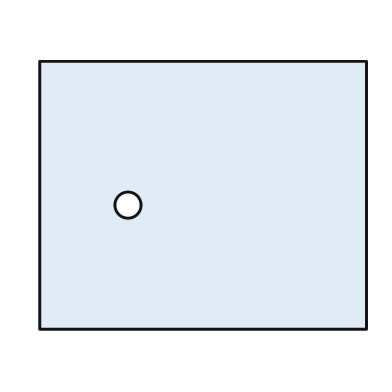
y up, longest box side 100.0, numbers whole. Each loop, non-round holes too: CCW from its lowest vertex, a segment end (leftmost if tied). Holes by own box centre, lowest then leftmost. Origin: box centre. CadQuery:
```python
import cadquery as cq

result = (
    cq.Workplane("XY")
    .moveTo(-50.0, -41.0)
    .lineTo(50.0, -41.0)
    .lineTo(50.0, 41.0)
    .lineTo(-50.0, 41.0)
    .close()
    .moveTo(-23.0, -3.0)
    .circle(4.0)
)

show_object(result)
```